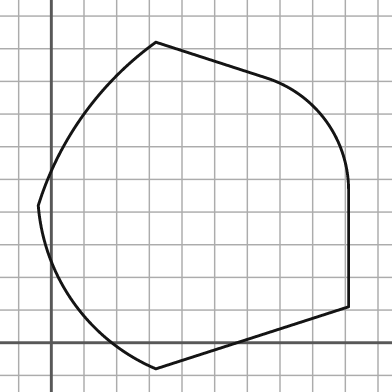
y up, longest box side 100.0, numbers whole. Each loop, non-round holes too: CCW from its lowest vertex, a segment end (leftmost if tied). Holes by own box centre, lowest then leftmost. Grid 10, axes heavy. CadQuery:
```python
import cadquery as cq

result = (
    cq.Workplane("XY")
    .moveTo(32.0, -8.0)
    .lineTo(91.0, 11.0)
    .lineTo(91.0, 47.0)
    .threePointArc((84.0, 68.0), (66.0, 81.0))
    .lineTo(32.0, 92.0)
    .threePointArc((10.0, 70.0), (-4.0, 42.0))
    .threePointArc((7.0, 12.0), (32.0, -8.0))
    .close()
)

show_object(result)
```